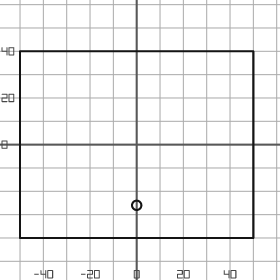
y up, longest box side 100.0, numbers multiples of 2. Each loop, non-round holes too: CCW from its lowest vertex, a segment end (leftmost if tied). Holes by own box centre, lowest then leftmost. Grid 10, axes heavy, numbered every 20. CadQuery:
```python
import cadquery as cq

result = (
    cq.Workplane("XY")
    .moveTo(-50.0, -40.0)
    .lineTo(50.0, -40.0)
    .lineTo(50.0, 40.0)
    .lineTo(-50.0, 40.0)
    .close()
    .moveTo(0.0, -26.0)
    .circle(2.0)
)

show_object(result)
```